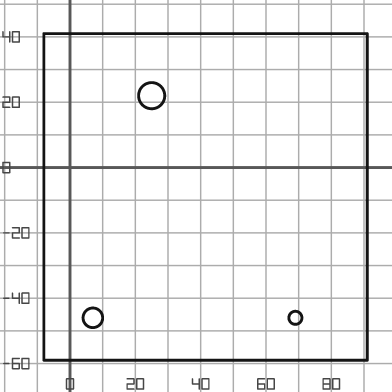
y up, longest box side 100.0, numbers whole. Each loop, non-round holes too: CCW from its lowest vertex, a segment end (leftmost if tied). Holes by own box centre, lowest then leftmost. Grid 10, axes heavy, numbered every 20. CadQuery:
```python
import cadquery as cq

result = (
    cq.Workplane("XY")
    .moveTo(-8.0, -59.0)
    .lineTo(91.0, -59.0)
    .lineTo(91.0, 41.0)
    .lineTo(-8.0, 41.0)
    .close()
    .moveTo(7.0, -46.0)
    .circle(3.0)
    .moveTo(69.0, -46.0)
    .circle(2.0)
    .moveTo(25.0, 22.0)
    .circle(4.0)
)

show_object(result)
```